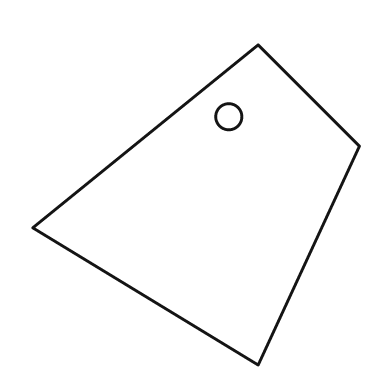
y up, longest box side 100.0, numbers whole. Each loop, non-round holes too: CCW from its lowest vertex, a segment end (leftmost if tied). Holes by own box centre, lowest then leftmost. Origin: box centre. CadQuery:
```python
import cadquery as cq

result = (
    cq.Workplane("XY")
    .moveTo(19.0, -49.0)
    .lineTo(50.0, 18.0)
    .lineTo(19.0, 49.0)
    .lineTo(-50.0, -7.0)
    .close()
    .moveTo(10.0, 27.0)
    .circle(4.0)
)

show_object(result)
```